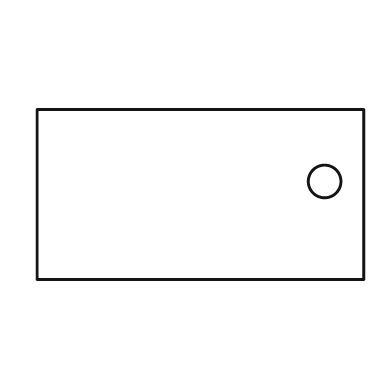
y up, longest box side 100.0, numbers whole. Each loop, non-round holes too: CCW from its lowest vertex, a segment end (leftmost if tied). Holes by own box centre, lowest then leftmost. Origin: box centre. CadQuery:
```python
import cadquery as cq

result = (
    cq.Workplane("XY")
    .moveTo(-50.0, -26.0)
    .lineTo(50.0, -26.0)
    .lineTo(50.0, 26.0)
    .lineTo(-50.0, 26.0)
    .close()
    .moveTo(38.0, 4.0)
    .circle(5.0)
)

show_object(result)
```